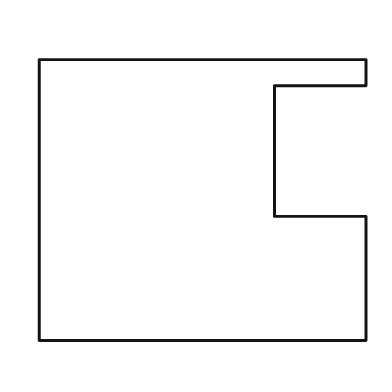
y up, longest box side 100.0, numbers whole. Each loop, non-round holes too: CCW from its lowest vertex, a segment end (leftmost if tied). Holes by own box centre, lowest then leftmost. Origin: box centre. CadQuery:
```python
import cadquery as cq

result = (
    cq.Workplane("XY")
    .moveTo(-50.0, -43.0)
    .lineTo(50.0, -43.0)
    .lineTo(50.0, -5.0)
    .lineTo(22.0, -5.0)
    .lineTo(22.0, 35.0)
    .lineTo(50.0, 35.0)
    .lineTo(50.0, 43.0)
    .lineTo(-50.0, 43.0)
    .close()
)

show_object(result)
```